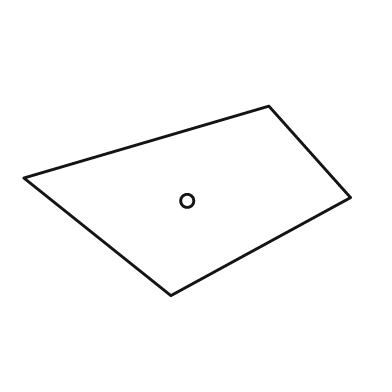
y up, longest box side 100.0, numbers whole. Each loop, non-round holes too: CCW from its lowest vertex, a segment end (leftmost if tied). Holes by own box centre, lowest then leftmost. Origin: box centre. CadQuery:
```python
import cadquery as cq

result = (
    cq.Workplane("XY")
    .moveTo(-5.0, -29.0)
    .lineTo(50.0, 1.0)
    .lineTo(25.0, 29.0)
    .lineTo(-50.0, 7.0)
    .close()
    .moveTo(0.0, 0.0)
    .circle(2.0)
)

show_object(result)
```